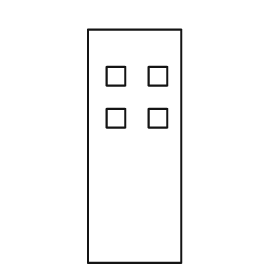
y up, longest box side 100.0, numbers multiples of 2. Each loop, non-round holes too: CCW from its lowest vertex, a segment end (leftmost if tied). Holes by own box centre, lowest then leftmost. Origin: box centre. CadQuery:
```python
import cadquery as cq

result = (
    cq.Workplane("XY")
    .moveTo(-20.0, -50.0)
    .lineTo(20.0, -50.0)
    .lineTo(20.0, 50.0)
    .lineTo(-20.0, 50.0)
    .close()
    .moveTo(-12.0, 8.0)
    .lineTo(-4.0, 8.0)
    .lineTo(-4.0, 16.0)
    .lineTo(-12.0, 16.0)
    .close()
    .moveTo(6.0, 8.0)
    .lineTo(14.0, 8.0)
    .lineTo(14.0, 16.0)
    .lineTo(6.0, 16.0)
    .close()
    .moveTo(-12.0, 26.0)
    .lineTo(-4.0, 26.0)
    .lineTo(-4.0, 34.0)
    .lineTo(-12.0, 34.0)
    .close()
    .moveTo(6.0, 26.0)
    .lineTo(14.0, 26.0)
    .lineTo(14.0, 34.0)
    .lineTo(6.0, 34.0)
    .close()
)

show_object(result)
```